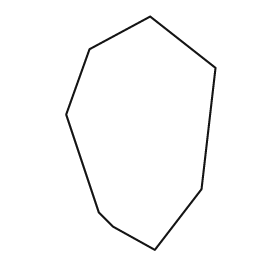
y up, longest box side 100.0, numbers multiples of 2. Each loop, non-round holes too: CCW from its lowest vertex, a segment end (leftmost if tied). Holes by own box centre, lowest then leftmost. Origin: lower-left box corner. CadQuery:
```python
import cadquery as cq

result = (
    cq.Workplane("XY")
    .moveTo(38.0, 0.0)
    .lineTo(58.0, 26.0)
    .lineTo(64.0, 78.0)
    .lineTo(36.0, 100.0)
    .lineTo(10.0, 86.0)
    .lineTo(0.0, 58.0)
    .lineTo(14.0, 16.0)
    .lineTo(20.0, 10.0)
    .close()
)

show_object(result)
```